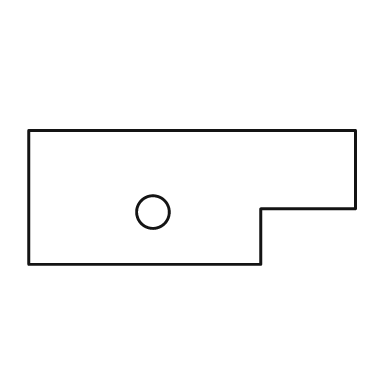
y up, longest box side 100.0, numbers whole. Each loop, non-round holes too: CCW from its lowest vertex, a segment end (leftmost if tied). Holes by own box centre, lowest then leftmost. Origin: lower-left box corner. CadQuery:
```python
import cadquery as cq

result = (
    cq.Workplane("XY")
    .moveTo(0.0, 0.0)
    .lineTo(71.0, 0.0)
    .lineTo(71.0, 17.0)
    .lineTo(100.0, 17.0)
    .lineTo(100.0, 41.0)
    .lineTo(0.0, 41.0)
    .close()
    .moveTo(38.0, 16.0)
    .circle(5.0)
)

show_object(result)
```